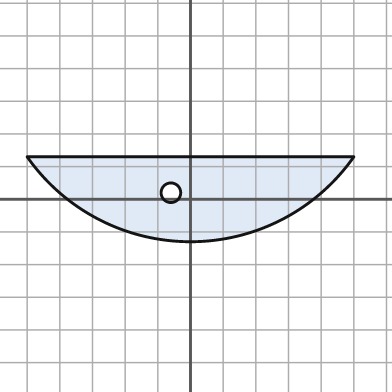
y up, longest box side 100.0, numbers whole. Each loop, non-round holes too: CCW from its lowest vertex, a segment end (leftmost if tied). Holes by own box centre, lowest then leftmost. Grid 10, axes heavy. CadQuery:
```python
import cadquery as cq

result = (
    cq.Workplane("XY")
    .moveTo(-50.0, 13.0)
    .threePointArc((0.0, -13.0), (50.0, 13.0))
    .close()
    .moveTo(-6.0, 2.0)
    .circle(3.0)
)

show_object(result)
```